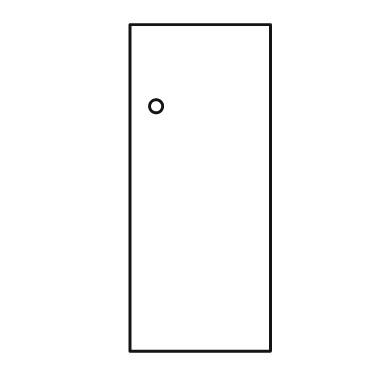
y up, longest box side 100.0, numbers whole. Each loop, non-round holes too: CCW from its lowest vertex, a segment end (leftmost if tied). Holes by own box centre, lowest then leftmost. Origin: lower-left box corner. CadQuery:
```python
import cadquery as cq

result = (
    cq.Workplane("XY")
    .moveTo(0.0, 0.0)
    .lineTo(43.0, 0.0)
    .lineTo(43.0, 100.0)
    .lineTo(0.0, 100.0)
    .close()
    .moveTo(8.0, 75.0)
    .circle(2.0)
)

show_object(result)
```